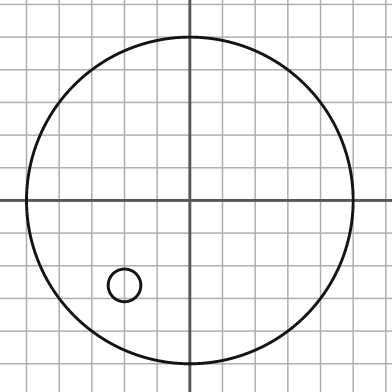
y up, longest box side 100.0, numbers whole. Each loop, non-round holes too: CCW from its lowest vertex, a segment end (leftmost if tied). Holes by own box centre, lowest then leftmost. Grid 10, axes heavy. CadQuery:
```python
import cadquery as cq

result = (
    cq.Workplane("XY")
    .moveTo(0.0, 0.0)
    .circle(50.0)
    .moveTo(-20.0, -26.0)
    .circle(5.0)
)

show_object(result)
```